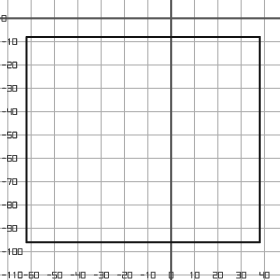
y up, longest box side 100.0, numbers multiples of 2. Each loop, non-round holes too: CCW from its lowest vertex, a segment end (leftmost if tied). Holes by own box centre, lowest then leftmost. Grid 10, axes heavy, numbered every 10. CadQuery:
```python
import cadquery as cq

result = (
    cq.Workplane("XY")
    .moveTo(-62.0, -96.0)
    .lineTo(38.0, -96.0)
    .lineTo(38.0, -8.0)
    .lineTo(-62.0, -8.0)
    .close()
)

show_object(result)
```